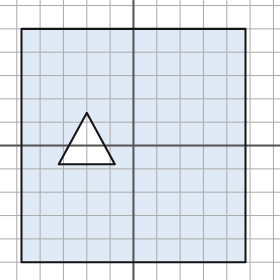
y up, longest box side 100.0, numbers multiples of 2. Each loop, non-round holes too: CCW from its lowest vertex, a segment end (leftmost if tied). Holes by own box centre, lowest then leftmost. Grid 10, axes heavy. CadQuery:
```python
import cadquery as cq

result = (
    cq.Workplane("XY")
    .moveTo(-48.0, -50.0)
    .lineTo(48.0, -50.0)
    .lineTo(48.0, 50.0)
    .lineTo(-48.0, 50.0)
    .close()
    .moveTo(-32.0, -8.0)
    .lineTo(-8.0, -8.0)
    .lineTo(-20.0, 14.0)
    .close()
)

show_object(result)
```